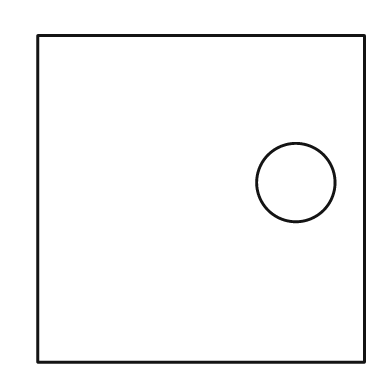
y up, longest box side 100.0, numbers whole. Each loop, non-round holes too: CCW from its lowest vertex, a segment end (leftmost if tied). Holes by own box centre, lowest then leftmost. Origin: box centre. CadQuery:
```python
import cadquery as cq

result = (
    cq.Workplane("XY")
    .moveTo(-50.0, -50.0)
    .lineTo(50.0, -50.0)
    .lineTo(50.0, 50.0)
    .lineTo(-50.0, 50.0)
    .close()
    .moveTo(29.0, 5.0)
    .circle(12.0)
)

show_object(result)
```